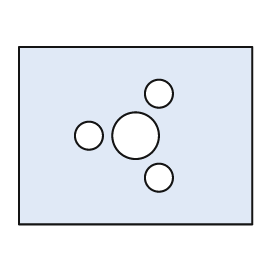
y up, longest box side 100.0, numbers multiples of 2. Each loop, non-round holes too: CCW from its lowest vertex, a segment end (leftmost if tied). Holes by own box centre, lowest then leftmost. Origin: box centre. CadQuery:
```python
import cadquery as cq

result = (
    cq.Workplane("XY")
    .moveTo(-50.0, -38.0)
    .lineTo(50.0, -38.0)
    .lineTo(50.0, 38.0)
    .lineTo(-50.0, 38.0)
    .close()
    .moveTo(10.0, -18.0)
    .circle(6.0)
    .moveTo(-20.0, 0.0)
    .circle(6.0)
    .moveTo(0.0, 0.0)
    .circle(10.0)
    .moveTo(10.0, 18.0)
    .circle(6.0)
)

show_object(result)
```